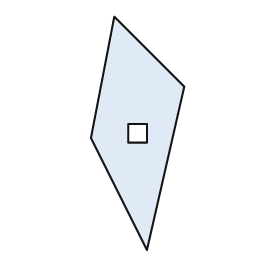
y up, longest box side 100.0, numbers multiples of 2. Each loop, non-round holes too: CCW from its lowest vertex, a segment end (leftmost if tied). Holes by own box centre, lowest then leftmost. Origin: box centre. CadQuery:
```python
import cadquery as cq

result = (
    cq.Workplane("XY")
    .moveTo(4.0, -50.0)
    .lineTo(20.0, 20.0)
    .lineTo(-10.0, 50.0)
    .lineTo(-20.0, -2.0)
    .close()
    .moveTo(-4.0, -4.0)
    .lineTo(4.0, -4.0)
    .lineTo(4.0, 4.0)
    .lineTo(-4.0, 4.0)
    .close()
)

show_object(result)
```